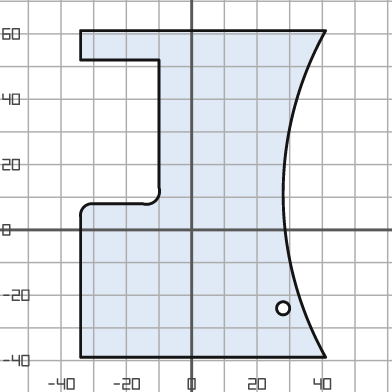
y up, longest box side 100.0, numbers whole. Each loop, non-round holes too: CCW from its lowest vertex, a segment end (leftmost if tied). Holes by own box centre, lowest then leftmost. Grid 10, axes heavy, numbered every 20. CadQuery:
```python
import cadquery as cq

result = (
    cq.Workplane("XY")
    .moveTo(-34.0, -39.0)
    .lineTo(41.0, -39.0)
    .threePointArc((28.0, 11.0), (41.0, 61.0))
    .lineTo(-34.0, 61.0)
    .lineTo(-34.0, 52.0)
    .lineTo(-10.0, 52.0)
    .lineTo(-10.0, 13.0)
    .threePointArc((-11.0, 9.0), (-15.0, 8.0))
    .lineTo(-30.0, 8.0)
    .threePointArc((-33.0, 7.0), (-34.0, 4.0))
    .close()
    .moveTo(28.0, -24.0)
    .circle(2.0)
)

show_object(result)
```